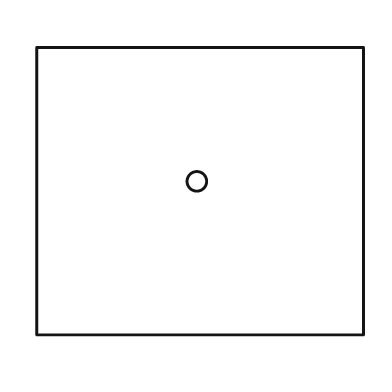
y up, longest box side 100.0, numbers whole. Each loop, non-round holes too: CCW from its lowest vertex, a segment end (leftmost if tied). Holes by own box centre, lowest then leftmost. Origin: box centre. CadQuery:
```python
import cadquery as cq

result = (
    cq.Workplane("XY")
    .moveTo(-50.0, -44.0)
    .lineTo(50.0, -44.0)
    .lineTo(50.0, 44.0)
    .lineTo(-50.0, 44.0)
    .close()
    .moveTo(-1.0, 3.0)
    .circle(3.0)
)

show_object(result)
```